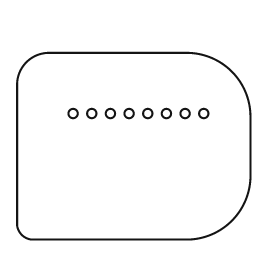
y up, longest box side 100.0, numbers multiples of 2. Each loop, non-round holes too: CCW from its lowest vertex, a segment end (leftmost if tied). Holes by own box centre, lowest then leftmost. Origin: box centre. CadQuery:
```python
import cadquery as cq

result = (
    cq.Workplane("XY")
    .moveTo(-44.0, -40.0)
    .lineTo(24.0, -40.0)
    .threePointArc((42.0, -32.0), (50.0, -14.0))
    .lineTo(50.0, 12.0)
    .threePointArc((42.0, 32.0), (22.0, 40.0))
    .lineTo(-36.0, 40.0)
    .threePointArc((-46.0, 36.0), (-50.0, 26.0))
    .lineTo(-50.0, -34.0)
    .threePointArc((-48.0, -38.0), (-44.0, -40.0))
    .close()
    .moveTo(-26.0, 14.0)
    .circle(2.0)
    .moveTo(-18.0, 14.0)
    .circle(2.0)
    .moveTo(-10.0, 14.0)
    .circle(2.0)
    .moveTo(-2.0, 14.0)
    .circle(2.0)
    .moveTo(6.0, 14.0)
    .circle(2.0)
    .moveTo(14.0, 14.0)
    .circle(2.0)
    .moveTo(22.0, 14.0)
    .circle(2.0)
    .moveTo(30.0, 14.0)
    .circle(2.0)
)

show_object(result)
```